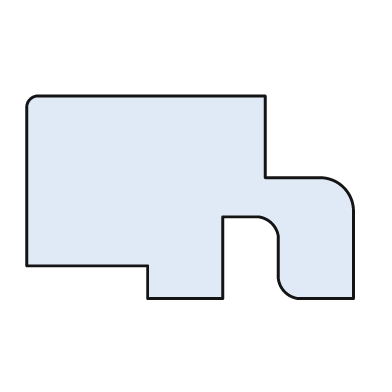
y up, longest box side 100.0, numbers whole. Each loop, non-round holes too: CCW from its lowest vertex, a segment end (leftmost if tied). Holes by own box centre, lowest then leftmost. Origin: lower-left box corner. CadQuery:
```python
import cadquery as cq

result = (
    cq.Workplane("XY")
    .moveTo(37.0, 0.0)
    .lineTo(60.0, 0.0)
    .lineTo(60.0, 25.0)
    .lineTo(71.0, 25.0)
    .threePointArc((75.0, 23.0), (77.0, 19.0))
    .lineTo(77.0, 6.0)
    .threePointArc((79.0, 2.0), (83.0, 0.0))
    .lineTo(100.0, 0.0)
    .lineTo(100.0, 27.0)
    .threePointArc((97.0, 34.0), (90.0, 37.0))
    .lineTo(73.0, 37.0)
    .lineTo(73.0, 62.0)
    .lineTo(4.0, 62.0)
    .threePointArc((1.0, 61.0), (0.0, 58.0))
    .lineTo(0.0, 10.0)
    .lineTo(37.0, 10.0)
    .close()
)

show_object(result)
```